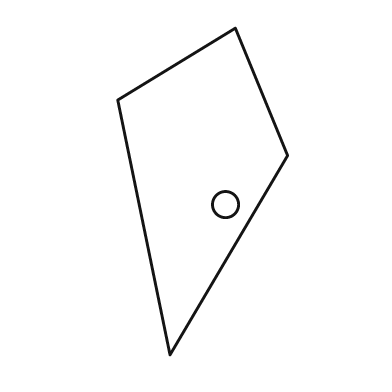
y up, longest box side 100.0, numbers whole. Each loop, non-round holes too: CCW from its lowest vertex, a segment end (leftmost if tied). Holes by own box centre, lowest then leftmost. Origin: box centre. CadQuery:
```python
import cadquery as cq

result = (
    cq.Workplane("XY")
    .moveTo(-10.0, -50.0)
    .lineTo(26.0, 11.0)
    .lineTo(10.0, 50.0)
    .lineTo(-26.0, 28.0)
    .close()
    .moveTo(7.0, -4.0)
    .circle(4.0)
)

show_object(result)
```